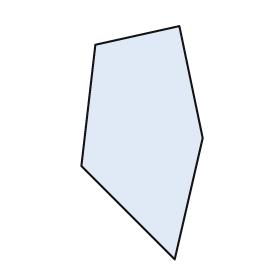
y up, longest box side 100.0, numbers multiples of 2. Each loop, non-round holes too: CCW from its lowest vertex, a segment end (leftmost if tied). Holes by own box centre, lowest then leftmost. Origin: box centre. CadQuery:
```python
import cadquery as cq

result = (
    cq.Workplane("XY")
    .moveTo(14.0, -50.0)
    .lineTo(26.0, 2.0)
    .lineTo(16.0, 50.0)
    .lineTo(-20.0, 42.0)
    .lineTo(-26.0, -10.0)
    .close()
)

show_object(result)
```